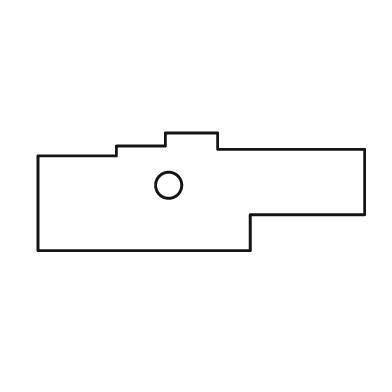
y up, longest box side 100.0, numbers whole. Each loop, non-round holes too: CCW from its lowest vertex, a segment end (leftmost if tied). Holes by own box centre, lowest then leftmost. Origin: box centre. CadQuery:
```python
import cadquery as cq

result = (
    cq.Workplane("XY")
    .moveTo(-50.0, -18.0)
    .lineTo(15.0, -18.0)
    .lineTo(15.0, -7.0)
    .lineTo(50.0, -7.0)
    .lineTo(50.0, 13.0)
    .lineTo(5.0, 13.0)
    .lineTo(5.0, 18.0)
    .lineTo(-11.0, 18.0)
    .lineTo(-11.0, 14.0)
    .lineTo(-26.0, 14.0)
    .lineTo(-26.0, 11.0)
    .lineTo(-50.0, 11.0)
    .close()
    .moveTo(-10.0, 2.0)
    .circle(4.0)
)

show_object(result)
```